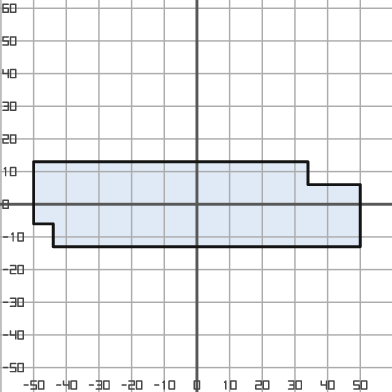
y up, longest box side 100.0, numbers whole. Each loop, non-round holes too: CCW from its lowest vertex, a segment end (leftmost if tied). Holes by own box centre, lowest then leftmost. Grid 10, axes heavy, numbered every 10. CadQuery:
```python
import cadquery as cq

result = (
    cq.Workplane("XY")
    .moveTo(-44.0, -13.0)
    .lineTo(50.0, -13.0)
    .lineTo(50.0, 6.0)
    .lineTo(34.0, 6.0)
    .lineTo(34.0, 13.0)
    .lineTo(-50.0, 13.0)
    .lineTo(-50.0, -6.0)
    .lineTo(-44.0, -6.0)
    .close()
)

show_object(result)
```